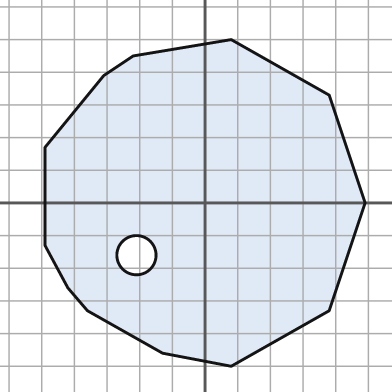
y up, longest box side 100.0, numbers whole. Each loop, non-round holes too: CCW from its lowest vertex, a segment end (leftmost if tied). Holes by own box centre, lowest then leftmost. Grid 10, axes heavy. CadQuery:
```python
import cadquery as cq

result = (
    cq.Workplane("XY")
    .moveTo(8.0, -50.0)
    .lineTo(38.0, -33.0)
    .lineTo(49.0, 0.0)
    .lineTo(38.0, 33.0)
    .lineTo(8.0, 50.0)
    .lineTo(-22.0, 45.0)
    .lineTo(-31.0, 39.0)
    .lineTo(-49.0, 17.0)
    .lineTo(-49.0, -13.0)
    .lineTo(-42.0, -26.0)
    .lineTo(-36.0, -33.0)
    .lineTo(-13.0, -46.0)
    .close()
    .moveTo(-21.0, -16.0)
    .circle(6.0)
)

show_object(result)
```